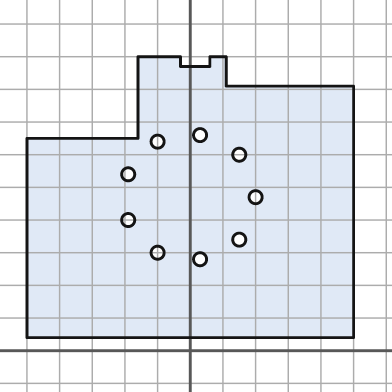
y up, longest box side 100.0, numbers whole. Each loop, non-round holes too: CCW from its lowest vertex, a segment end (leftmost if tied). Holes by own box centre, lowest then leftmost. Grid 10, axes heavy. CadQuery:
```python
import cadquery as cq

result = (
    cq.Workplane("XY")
    .moveTo(-50.0, 4.0)
    .lineTo(50.0, 4.0)
    .lineTo(50.0, 81.0)
    .lineTo(11.0, 81.0)
    .lineTo(11.0, 90.0)
    .lineTo(6.0, 90.0)
    .lineTo(6.0, 87.0)
    .lineTo(-3.0, 87.0)
    .lineTo(-3.0, 90.0)
    .lineTo(-16.0, 90.0)
    .lineTo(-16.0, 65.0)
    .lineTo(-50.0, 65.0)
    .close()
    .moveTo(3.0, 28.0)
    .circle(2.0)
    .moveTo(-10.0, 30.0)
    .circle(2.0)
    .moveTo(15.0, 34.0)
    .circle(2.0)
    .moveTo(-19.0, 40.0)
    .circle(2.0)
    .moveTo(20.0, 47.0)
    .circle(2.0)
    .moveTo(-19.0, 54.0)
    .circle(2.0)
    .moveTo(15.0, 60.0)
    .circle(2.0)
    .moveTo(-10.0, 64.0)
    .circle(2.0)
    .moveTo(3.0, 66.0)
    .circle(2.0)
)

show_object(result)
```